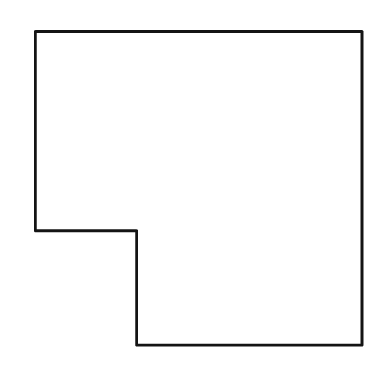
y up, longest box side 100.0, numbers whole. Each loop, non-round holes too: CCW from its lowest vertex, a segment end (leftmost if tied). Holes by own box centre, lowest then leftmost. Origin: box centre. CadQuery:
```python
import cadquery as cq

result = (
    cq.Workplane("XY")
    .moveTo(-19.0, -48.0)
    .lineTo(50.0, -48.0)
    .lineTo(50.0, 48.0)
    .lineTo(-50.0, 48.0)
    .lineTo(-50.0, -13.0)
    .lineTo(-19.0, -13.0)
    .close()
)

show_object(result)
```